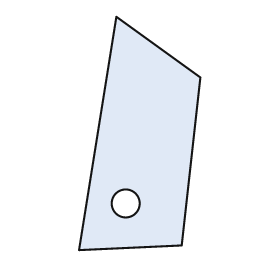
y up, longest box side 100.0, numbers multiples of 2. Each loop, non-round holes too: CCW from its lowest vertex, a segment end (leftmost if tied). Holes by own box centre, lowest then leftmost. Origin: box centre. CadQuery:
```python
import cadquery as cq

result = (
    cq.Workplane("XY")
    .moveTo(-26.0, -50.0)
    .lineTo(18.0, -48.0)
    .lineTo(26.0, 24.0)
    .lineTo(-10.0, 50.0)
    .close()
    .moveTo(-6.0, -30.0)
    .circle(6.0)
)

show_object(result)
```